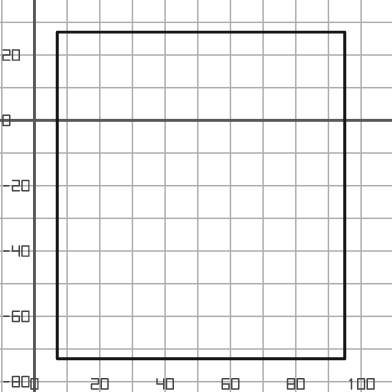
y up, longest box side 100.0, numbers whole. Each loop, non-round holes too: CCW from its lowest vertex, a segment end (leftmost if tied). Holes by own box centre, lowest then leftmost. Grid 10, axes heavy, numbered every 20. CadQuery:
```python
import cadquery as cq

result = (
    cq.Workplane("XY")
    .moveTo(7.0, -73.0)
    .lineTo(95.0, -73.0)
    .lineTo(95.0, 27.0)
    .lineTo(7.0, 27.0)
    .close()
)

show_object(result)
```